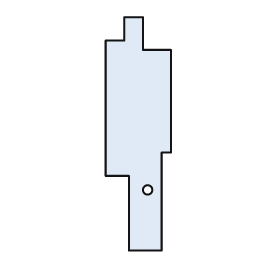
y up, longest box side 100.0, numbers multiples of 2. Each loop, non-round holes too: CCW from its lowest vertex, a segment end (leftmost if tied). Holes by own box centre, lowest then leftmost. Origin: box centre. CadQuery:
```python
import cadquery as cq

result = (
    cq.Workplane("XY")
    .moveTo(-4.0, -50.0)
    .lineTo(10.0, -50.0)
    .lineTo(10.0, -8.0)
    .lineTo(14.0, -8.0)
    .lineTo(14.0, 36.0)
    .lineTo(2.0, 36.0)
    .lineTo(2.0, 50.0)
    .lineTo(-6.0, 50.0)
    .lineTo(-6.0, 40.0)
    .lineTo(-14.0, 40.0)
    .lineTo(-14.0, -18.0)
    .lineTo(-4.0, -18.0)
    .close()
    .moveTo(4.0, -24.0)
    .circle(2.0)
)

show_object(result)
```